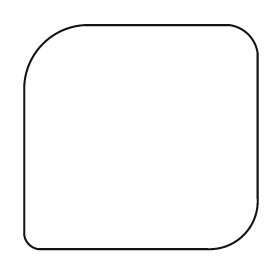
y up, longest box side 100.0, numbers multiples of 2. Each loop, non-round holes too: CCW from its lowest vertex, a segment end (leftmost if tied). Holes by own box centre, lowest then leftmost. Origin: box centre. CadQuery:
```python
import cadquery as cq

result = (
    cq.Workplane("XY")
    .moveTo(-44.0, -48.0)
    .lineTo(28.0, -48.0)
    .threePointArc((44.0, -42.0), (50.0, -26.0))
    .lineTo(50.0, 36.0)
    .threePointArc((46.0, 44.0), (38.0, 48.0))
    .lineTo(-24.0, 48.0)
    .threePointArc((-42.0, 40.0), (-50.0, 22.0))
    .lineTo(-50.0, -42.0)
    .threePointArc((-48.0, -46.0), (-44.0, -48.0))
    .close()
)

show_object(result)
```